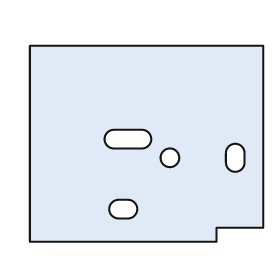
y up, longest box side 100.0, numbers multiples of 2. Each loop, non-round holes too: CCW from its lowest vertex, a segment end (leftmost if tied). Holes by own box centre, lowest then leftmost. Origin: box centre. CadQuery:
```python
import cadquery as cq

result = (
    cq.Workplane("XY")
    .moveTo(-50.0, -42.0)
    .lineTo(30.0, -42.0)
    .lineTo(30.0, -36.0)
    .lineTo(50.0, -36.0)
    .lineTo(50.0, 42.0)
    .lineTo(-50.0, 42.0)
    .close()
    .moveTo(-12.0, -32.0)
    .lineTo(-8.0, -32.0)
    .threePointArc((-4.0, -28.0), (-8.0, -24.0))
    .lineTo(-12.0, -24.0)
    .threePointArc((-16.0, -28.0), (-12.0, -32.0))
    .close()
    .moveTo(10.0, -6.0)
    .circle(4.0)
    .moveTo(34.0, -8.0)
    .threePointArc((38.0, -12.0), (42.0, -8.0))
    .lineTo(42.0, -4.0)
    .threePointArc((38.0, 0.0), (34.0, -4.0))
    .close()
    .moveTo(-14.0, -2.0)
    .lineTo(-2.0, -2.0)
    .threePointArc((2.0, 2.0), (-2.0, 6.0))
    .lineTo(-14.0, 6.0)
    .threePointArc((-18.0, 2.0), (-14.0, -2.0))
    .close()
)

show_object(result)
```